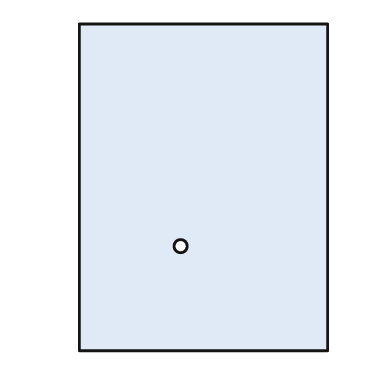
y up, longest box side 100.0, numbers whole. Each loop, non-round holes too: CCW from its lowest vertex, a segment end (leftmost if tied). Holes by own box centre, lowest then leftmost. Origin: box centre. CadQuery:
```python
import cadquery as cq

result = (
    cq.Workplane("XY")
    .moveTo(-38.0, -50.0)
    .lineTo(38.0, -50.0)
    .lineTo(38.0, 50.0)
    .lineTo(-38.0, 50.0)
    .close()
    .moveTo(-7.0, -18.0)
    .circle(2.0)
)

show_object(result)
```